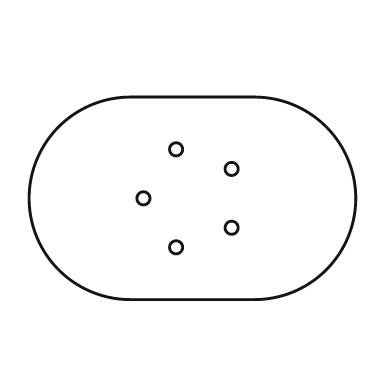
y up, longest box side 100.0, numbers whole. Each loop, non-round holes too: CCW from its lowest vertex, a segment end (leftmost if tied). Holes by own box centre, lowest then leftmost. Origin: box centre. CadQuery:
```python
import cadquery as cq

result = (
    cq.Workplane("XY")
    .moveTo(-19.0, -31.0)
    .lineTo(19.0, -31.0)
    .threePointArc((50.0, 0.0), (19.0, 31.0))
    .lineTo(-19.0, 31.0)
    .threePointArc((-50.0, 0.0), (-19.0, -31.0))
    .close()
    .moveTo(-5.0, -15.0)
    .circle(2.0)
    .moveTo(12.0, -9.0)
    .circle(2.0)
    .moveTo(-15.0, 0.0)
    .circle(2.0)
    .moveTo(12.0, 9.0)
    .circle(2.0)
    .moveTo(-5.0, 15.0)
    .circle(2.0)
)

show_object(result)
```